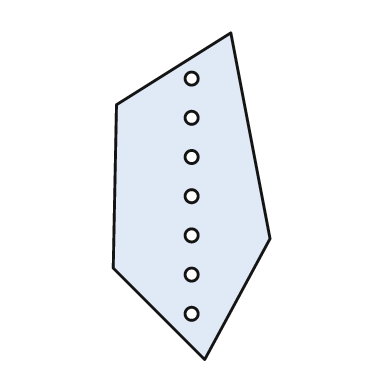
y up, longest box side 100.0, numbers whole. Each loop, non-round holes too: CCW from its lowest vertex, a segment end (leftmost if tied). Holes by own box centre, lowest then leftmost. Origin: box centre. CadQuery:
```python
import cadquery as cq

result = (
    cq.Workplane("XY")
    .moveTo(4.0, -50.0)
    .lineTo(24.0, -13.0)
    .lineTo(12.0, 50.0)
    .lineTo(-23.0, 28.0)
    .lineTo(-24.0, -22.0)
    .close()
    .moveTo(0.0, -36.0)
    .circle(2.0)
    .moveTo(0.0, -24.0)
    .circle(2.0)
    .moveTo(0.0, -12.0)
    .circle(2.0)
    .moveTo(0.0, 0.0)
    .circle(2.0)
    .moveTo(0.0, 12.0)
    .circle(2.0)
    .moveTo(0.0, 24.0)
    .circle(2.0)
    .moveTo(0.0, 36.0)
    .circle(2.0)
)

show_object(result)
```